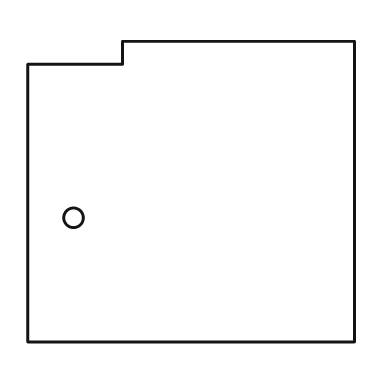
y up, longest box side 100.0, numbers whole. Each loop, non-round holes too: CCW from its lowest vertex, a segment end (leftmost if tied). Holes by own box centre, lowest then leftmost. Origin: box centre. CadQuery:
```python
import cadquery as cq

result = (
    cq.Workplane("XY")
    .moveTo(-50.0, -46.0)
    .lineTo(50.0, -46.0)
    .lineTo(50.0, 46.0)
    .lineTo(-21.0, 46.0)
    .lineTo(-21.0, 39.0)
    .lineTo(-50.0, 39.0)
    .close()
    .moveTo(-36.0, -8.0)
    .circle(3.0)
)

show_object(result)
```